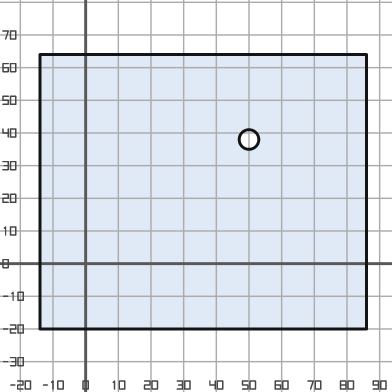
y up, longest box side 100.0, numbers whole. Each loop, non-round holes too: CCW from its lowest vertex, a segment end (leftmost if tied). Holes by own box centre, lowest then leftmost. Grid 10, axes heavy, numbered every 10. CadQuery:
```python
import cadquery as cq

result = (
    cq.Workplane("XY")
    .moveTo(-14.0, -20.0)
    .lineTo(86.0, -20.0)
    .lineTo(86.0, 64.0)
    .lineTo(-14.0, 64.0)
    .close()
    .moveTo(50.0, 38.0)
    .circle(3.0)
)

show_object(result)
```